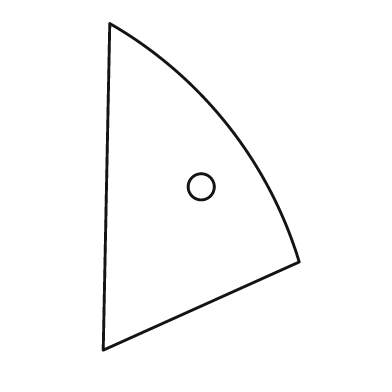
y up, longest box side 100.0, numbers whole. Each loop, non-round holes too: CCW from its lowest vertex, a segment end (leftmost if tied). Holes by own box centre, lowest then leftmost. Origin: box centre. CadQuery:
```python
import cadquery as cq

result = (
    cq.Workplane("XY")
    .moveTo(-30.0, -50.0)
    .lineTo(30.0, -23.0)
    .threePointArc((8.0, 19.0), (-28.0, 50.0))
    .close()
    .moveTo(0.0, 0.0)
    .circle(4.0)
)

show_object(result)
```